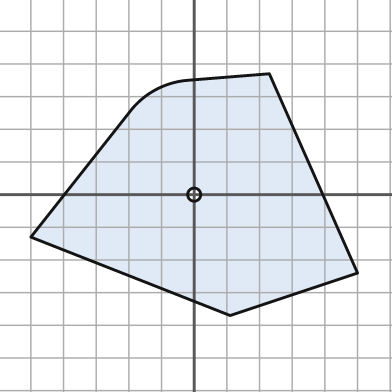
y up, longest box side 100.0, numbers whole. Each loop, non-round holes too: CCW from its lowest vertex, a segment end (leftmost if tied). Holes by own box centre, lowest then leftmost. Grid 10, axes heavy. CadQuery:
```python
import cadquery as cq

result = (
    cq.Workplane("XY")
    .moveTo(11.0, -37.0)
    .lineTo(50.0, -24.0)
    .lineTo(23.0, 37.0)
    .lineTo(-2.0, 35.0)
    .threePointArc((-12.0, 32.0), (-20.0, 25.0))
    .lineTo(-50.0, -13.0)
    .close()
    .moveTo(0.0, 0.0)
    .circle(2.0)
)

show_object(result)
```